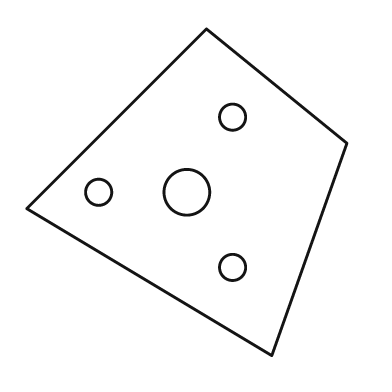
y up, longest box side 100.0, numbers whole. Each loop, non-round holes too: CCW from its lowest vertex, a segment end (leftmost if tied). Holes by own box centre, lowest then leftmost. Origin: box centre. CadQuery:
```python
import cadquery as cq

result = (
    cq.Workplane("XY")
    .moveTo(26.0, -50.0)
    .lineTo(49.0, 15.0)
    .lineTo(6.0, 50.0)
    .lineTo(-49.0, -5.0)
    .close()
    .moveTo(14.0, -23.0)
    .circle(4.0)
    .moveTo(-27.0, 0.0)
    .circle(4.0)
    .moveTo(0.0, 0.0)
    .circle(7.0)
    .moveTo(14.0, 23.0)
    .circle(4.0)
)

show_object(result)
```